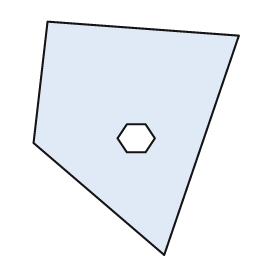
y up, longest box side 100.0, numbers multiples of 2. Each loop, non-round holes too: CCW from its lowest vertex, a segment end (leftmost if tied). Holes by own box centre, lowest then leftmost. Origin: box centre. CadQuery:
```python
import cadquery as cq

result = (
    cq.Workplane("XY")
    .moveTo(12.0, -50.0)
    .lineTo(44.0, 44.0)
    .lineTo(-38.0, 50.0)
    .lineTo(-44.0, -2.0)
    .close()
    .moveTo(-4.0, -6.0)
    .lineTo(4.0, -6.0)
    .lineTo(8.0, 0.0)
    .lineTo(4.0, 6.0)
    .lineTo(-4.0, 6.0)
    .lineTo(-8.0, 0.0)
    .close()
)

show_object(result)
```